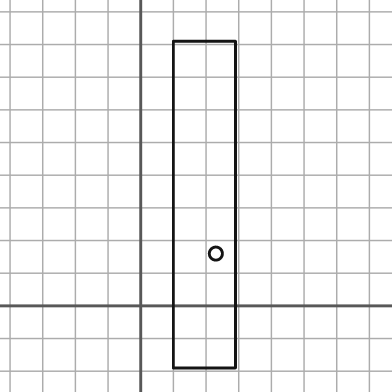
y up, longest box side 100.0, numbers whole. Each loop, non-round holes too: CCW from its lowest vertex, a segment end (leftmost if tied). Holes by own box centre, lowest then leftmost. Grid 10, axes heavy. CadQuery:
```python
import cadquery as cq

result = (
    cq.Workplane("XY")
    .moveTo(10.0, -19.0)
    .lineTo(29.0, -19.0)
    .lineTo(29.0, 81.0)
    .lineTo(10.0, 81.0)
    .close()
    .moveTo(23.0, 16.0)
    .circle(2.0)
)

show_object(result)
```